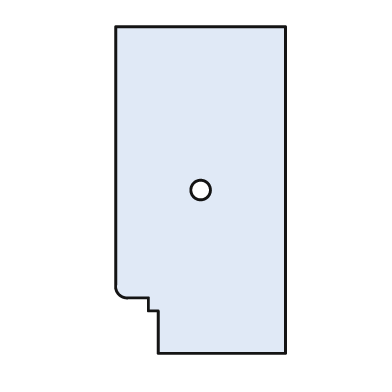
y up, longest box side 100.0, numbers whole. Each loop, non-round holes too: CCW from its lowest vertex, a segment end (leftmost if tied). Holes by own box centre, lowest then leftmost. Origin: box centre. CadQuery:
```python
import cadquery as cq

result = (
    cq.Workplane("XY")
    .moveTo(-13.0, -50.0)
    .lineTo(26.0, -50.0)
    .lineTo(26.0, 50.0)
    .lineTo(-26.0, 50.0)
    .lineTo(-26.0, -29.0)
    .threePointArc((-25.0, -32.0), (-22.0, -33.0))
    .lineTo(-16.0, -33.0)
    .lineTo(-16.0, -37.0)
    .lineTo(-13.0, -37.0)
    .close()
    .moveTo(0.0, 0.0)
    .circle(3.0)
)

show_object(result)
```